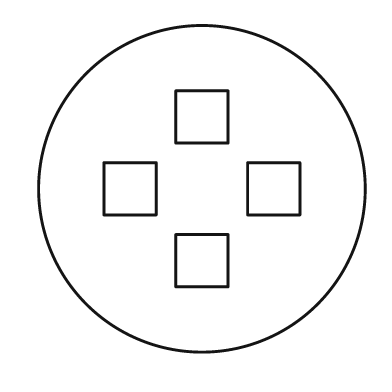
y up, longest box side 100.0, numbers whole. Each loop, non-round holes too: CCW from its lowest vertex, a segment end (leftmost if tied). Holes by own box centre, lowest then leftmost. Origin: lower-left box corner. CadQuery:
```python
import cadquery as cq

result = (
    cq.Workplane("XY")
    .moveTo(50.0, 50.0)
    .circle(50.0)
    .moveTo(42.0, 20.0)
    .lineTo(58.0, 20.0)
    .lineTo(58.0, 36.0)
    .lineTo(42.0, 36.0)
    .close()
    .moveTo(20.0, 42.0)
    .lineTo(36.0, 42.0)
    .lineTo(36.0, 58.0)
    .lineTo(20.0, 58.0)
    .close()
    .moveTo(64.0, 42.0)
    .lineTo(80.0, 42.0)
    .lineTo(80.0, 58.0)
    .lineTo(64.0, 58.0)
    .close()
    .moveTo(42.0, 64.0)
    .lineTo(58.0, 64.0)
    .lineTo(58.0, 80.0)
    .lineTo(42.0, 80.0)
    .close()
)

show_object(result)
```